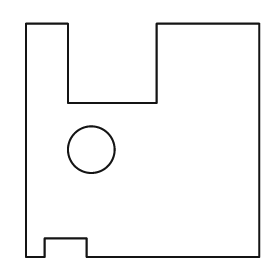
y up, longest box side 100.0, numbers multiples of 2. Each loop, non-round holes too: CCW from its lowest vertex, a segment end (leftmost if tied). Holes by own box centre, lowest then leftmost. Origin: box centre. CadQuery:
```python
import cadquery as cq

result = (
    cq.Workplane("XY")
    .moveTo(-50.0, -50.0)
    .lineTo(-42.0, -50.0)
    .lineTo(-42.0, -42.0)
    .lineTo(-24.0, -42.0)
    .lineTo(-24.0, -50.0)
    .lineTo(50.0, -50.0)
    .lineTo(50.0, 50.0)
    .lineTo(6.0, 50.0)
    .lineTo(6.0, 16.0)
    .lineTo(-32.0, 16.0)
    .lineTo(-32.0, 50.0)
    .lineTo(-50.0, 50.0)
    .close()
    .moveTo(-22.0, -4.0)
    .circle(10.0)
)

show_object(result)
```